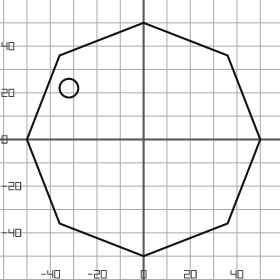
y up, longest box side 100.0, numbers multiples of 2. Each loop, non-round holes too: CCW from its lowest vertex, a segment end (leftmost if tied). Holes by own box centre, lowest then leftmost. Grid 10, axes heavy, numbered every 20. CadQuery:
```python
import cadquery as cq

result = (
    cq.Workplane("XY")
    .moveTo(0.0, -50.0)
    .lineTo(36.0, -36.0)
    .lineTo(50.0, 0.0)
    .lineTo(36.0, 36.0)
    .lineTo(0.0, 50.0)
    .lineTo(-36.0, 36.0)
    .lineTo(-50.0, 0.0)
    .lineTo(-36.0, -36.0)
    .close()
    .moveTo(-32.0, 22.0)
    .circle(4.0)
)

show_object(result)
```